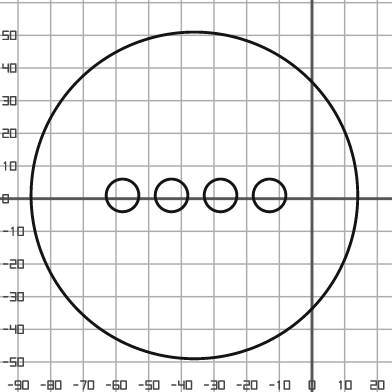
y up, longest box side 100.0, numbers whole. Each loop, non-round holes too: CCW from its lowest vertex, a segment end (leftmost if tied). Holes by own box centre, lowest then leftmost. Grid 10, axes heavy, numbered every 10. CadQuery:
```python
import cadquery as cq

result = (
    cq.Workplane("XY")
    .moveTo(-36.0, 1.0)
    .circle(50.0)
    .moveTo(-58.0, 1.0)
    .circle(5.0)
    .moveTo(-43.0, 1.0)
    .circle(5.0)
    .moveTo(-28.0, 1.0)
    .circle(5.0)
    .moveTo(-13.0, 1.0)
    .circle(5.0)
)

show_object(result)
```